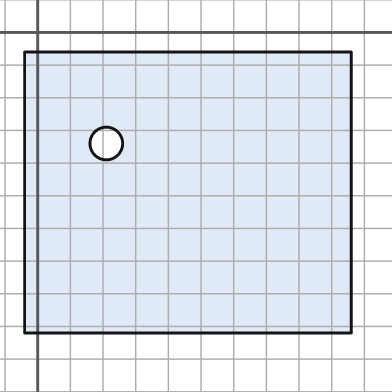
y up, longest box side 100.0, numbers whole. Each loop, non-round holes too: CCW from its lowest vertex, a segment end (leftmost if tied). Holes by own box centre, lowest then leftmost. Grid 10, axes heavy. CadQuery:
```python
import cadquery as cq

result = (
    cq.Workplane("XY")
    .moveTo(-4.0, -92.0)
    .lineTo(96.0, -92.0)
    .lineTo(96.0, -6.0)
    .lineTo(-4.0, -6.0)
    .close()
    .moveTo(21.0, -34.0)
    .circle(5.0)
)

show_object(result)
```